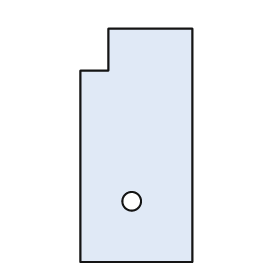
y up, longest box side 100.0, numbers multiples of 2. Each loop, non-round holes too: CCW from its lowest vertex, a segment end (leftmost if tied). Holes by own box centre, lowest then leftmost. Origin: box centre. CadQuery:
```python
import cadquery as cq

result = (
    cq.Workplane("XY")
    .moveTo(-24.0, -50.0)
    .lineTo(24.0, -50.0)
    .lineTo(24.0, 50.0)
    .lineTo(-12.0, 50.0)
    .lineTo(-12.0, 32.0)
    .lineTo(-24.0, 32.0)
    .close()
    .moveTo(-2.0, -24.0)
    .circle(4.0)
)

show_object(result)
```